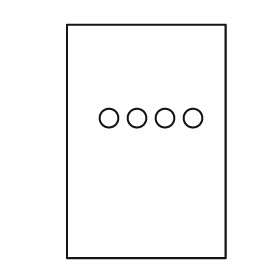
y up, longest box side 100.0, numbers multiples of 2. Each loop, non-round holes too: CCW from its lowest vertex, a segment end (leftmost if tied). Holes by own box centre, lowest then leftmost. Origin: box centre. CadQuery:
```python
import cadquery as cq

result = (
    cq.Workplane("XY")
    .moveTo(-34.0, -50.0)
    .lineTo(34.0, -50.0)
    .lineTo(34.0, 50.0)
    .lineTo(-34.0, 50.0)
    .close()
    .moveTo(-16.0, 10.0)
    .circle(4.0)
    .moveTo(-4.0, 10.0)
    .circle(4.0)
    .moveTo(8.0, 10.0)
    .circle(4.0)
    .moveTo(20.0, 10.0)
    .circle(4.0)
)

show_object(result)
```